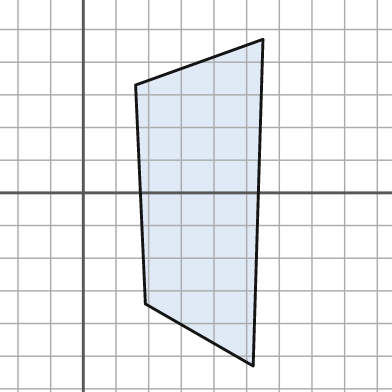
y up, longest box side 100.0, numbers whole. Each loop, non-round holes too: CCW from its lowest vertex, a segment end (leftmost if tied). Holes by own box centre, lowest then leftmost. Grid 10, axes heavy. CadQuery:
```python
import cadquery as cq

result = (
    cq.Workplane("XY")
    .moveTo(52.0, -53.0)
    .lineTo(55.0, 47.0)
    .lineTo(16.0, 33.0)
    .lineTo(19.0, -34.0)
    .close()
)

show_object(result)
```